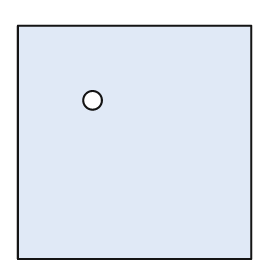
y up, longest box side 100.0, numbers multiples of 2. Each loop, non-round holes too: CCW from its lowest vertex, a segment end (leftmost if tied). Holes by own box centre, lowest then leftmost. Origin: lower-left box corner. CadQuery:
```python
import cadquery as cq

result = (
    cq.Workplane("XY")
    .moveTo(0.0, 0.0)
    .lineTo(100.0, 0.0)
    .lineTo(100.0, 100.0)
    .lineTo(0.0, 100.0)
    .close()
    .moveTo(32.0, 68.0)
    .circle(4.0)
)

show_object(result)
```